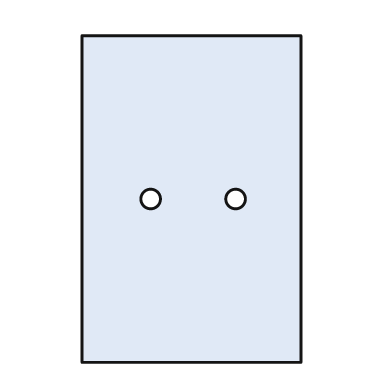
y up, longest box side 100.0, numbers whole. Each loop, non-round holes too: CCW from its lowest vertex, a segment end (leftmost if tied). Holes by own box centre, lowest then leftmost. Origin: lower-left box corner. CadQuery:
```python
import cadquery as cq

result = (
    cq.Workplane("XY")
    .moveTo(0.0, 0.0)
    .lineTo(67.0, 0.0)
    .lineTo(67.0, 100.0)
    .lineTo(0.0, 100.0)
    .close()
    .moveTo(21.0, 50.0)
    .circle(3.0)
    .moveTo(47.0, 50.0)
    .circle(3.0)
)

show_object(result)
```